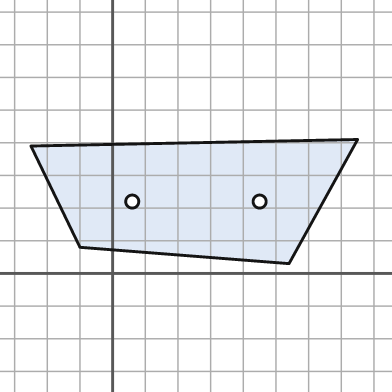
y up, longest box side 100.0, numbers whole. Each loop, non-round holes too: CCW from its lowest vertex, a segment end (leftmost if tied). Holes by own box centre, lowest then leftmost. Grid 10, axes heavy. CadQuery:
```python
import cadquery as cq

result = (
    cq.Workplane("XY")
    .moveTo(54.0, 3.0)
    .lineTo(75.0, 41.0)
    .lineTo(-25.0, 39.0)
    .lineTo(-10.0, 8.0)
    .close()
    .moveTo(6.0, 22.0)
    .circle(2.0)
    .moveTo(45.0, 22.0)
    .circle(2.0)
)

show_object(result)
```